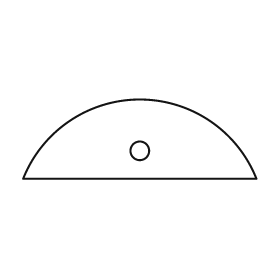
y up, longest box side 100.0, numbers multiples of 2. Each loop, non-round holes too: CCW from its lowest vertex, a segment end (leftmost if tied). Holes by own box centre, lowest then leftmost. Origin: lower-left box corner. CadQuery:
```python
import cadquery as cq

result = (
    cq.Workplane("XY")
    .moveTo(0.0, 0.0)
    .lineTo(100.0, 0.0)
    .threePointArc((50.0, 34.0), (0.0, 0.0))
    .close()
    .moveTo(50.0, 12.0)
    .circle(4.0)
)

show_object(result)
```